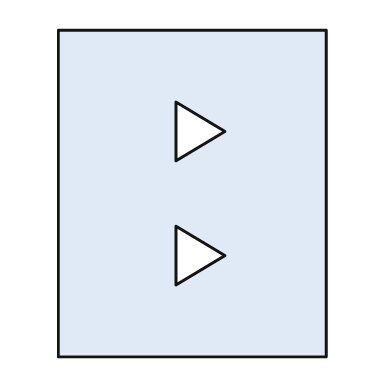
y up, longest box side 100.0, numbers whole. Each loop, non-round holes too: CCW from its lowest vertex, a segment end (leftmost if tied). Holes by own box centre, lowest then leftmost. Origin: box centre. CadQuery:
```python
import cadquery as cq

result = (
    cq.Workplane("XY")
    .moveTo(-41.0, -50.0)
    .lineTo(41.0, -50.0)
    .lineTo(41.0, 50.0)
    .lineTo(-41.0, 50.0)
    .close()
    .moveTo(-5.0, -28.0)
    .lineTo(10.0, -19.0)
    .lineTo(-5.0, -10.0)
    .close()
    .moveTo(-5.0, 10.0)
    .lineTo(10.0, 19.0)
    .lineTo(-5.0, 28.0)
    .close()
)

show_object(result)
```